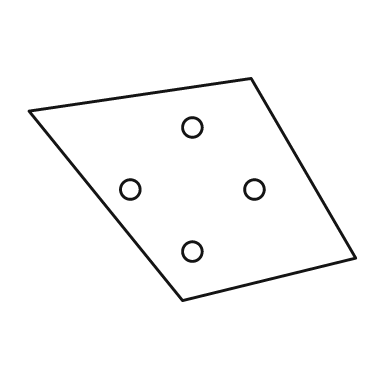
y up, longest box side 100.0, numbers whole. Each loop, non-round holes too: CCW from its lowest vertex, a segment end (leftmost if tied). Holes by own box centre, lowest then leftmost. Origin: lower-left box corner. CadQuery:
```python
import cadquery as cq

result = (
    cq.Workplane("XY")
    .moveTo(47.0, 0.0)
    .lineTo(100.0, 13.0)
    .lineTo(68.0, 68.0)
    .lineTo(0.0, 58.0)
    .close()
    .moveTo(50.0, 15.0)
    .circle(3.0)
    .moveTo(31.0, 34.0)
    .circle(3.0)
    .moveTo(69.0, 34.0)
    .circle(3.0)
    .moveTo(50.0, 53.0)
    .circle(3.0)
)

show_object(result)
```